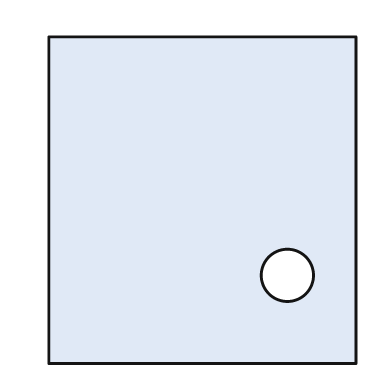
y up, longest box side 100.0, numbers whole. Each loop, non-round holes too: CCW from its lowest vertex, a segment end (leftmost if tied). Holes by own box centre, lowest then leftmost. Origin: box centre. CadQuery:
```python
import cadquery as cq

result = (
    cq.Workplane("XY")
    .moveTo(-47.0, -50.0)
    .lineTo(47.0, -50.0)
    .lineTo(47.0, 50.0)
    .lineTo(-47.0, 50.0)
    .close()
    .moveTo(26.0, -23.0)
    .circle(8.0)
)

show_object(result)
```